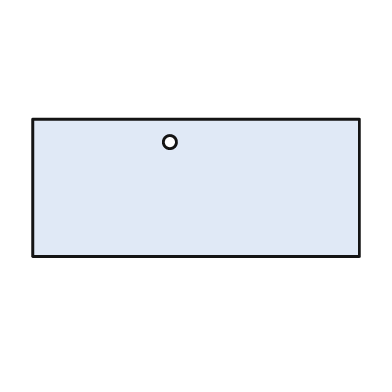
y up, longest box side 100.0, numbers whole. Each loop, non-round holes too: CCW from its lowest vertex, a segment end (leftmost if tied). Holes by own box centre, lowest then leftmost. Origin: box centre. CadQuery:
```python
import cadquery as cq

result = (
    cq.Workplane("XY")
    .moveTo(-50.0, -21.0)
    .lineTo(50.0, -21.0)
    .lineTo(50.0, 21.0)
    .lineTo(-50.0, 21.0)
    .close()
    .moveTo(-8.0, 14.0)
    .circle(2.0)
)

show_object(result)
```